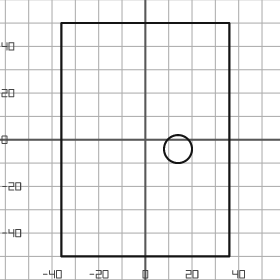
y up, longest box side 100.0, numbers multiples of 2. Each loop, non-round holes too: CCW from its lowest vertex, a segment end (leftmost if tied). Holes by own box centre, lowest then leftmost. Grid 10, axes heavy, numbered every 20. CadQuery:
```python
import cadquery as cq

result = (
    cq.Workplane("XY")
    .moveTo(-36.0, -50.0)
    .lineTo(36.0, -50.0)
    .lineTo(36.0, 50.0)
    .lineTo(-36.0, 50.0)
    .close()
    .moveTo(14.0, -4.0)
    .circle(6.0)
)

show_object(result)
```